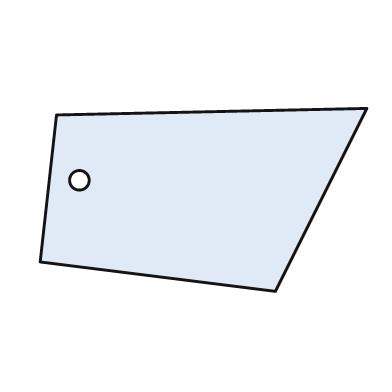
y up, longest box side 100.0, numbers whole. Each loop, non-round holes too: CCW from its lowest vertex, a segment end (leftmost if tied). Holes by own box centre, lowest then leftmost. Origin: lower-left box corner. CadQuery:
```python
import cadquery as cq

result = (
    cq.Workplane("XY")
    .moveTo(72.0, 0.0)
    .lineTo(100.0, 56.0)
    .lineTo(5.0, 54.0)
    .lineTo(0.0, 9.0)
    .close()
    .moveTo(12.0, 34.0)
    .circle(3.0)
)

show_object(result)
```